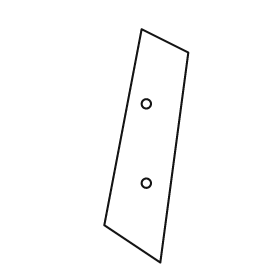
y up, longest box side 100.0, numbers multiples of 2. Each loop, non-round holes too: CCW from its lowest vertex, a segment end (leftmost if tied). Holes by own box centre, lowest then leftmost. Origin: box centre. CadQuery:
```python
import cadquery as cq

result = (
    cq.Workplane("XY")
    .moveTo(6.0, -50.0)
    .lineTo(18.0, 40.0)
    .lineTo(-2.0, 50.0)
    .lineTo(-18.0, -34.0)
    .close()
    .moveTo(0.0, -16.0)
    .circle(2.0)
    .moveTo(0.0, 18.0)
    .circle(2.0)
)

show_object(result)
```